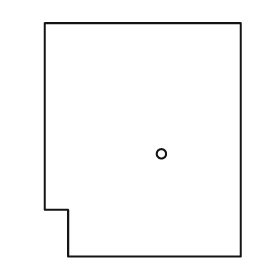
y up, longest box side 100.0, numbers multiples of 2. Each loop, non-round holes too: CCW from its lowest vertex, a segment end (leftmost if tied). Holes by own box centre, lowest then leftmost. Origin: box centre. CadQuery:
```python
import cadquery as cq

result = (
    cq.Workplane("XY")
    .moveTo(-32.0, -50.0)
    .lineTo(42.0, -50.0)
    .lineTo(42.0, 50.0)
    .lineTo(-42.0, 50.0)
    .lineTo(-42.0, -30.0)
    .lineTo(-32.0, -30.0)
    .close()
    .moveTo(8.0, -6.0)
    .circle(2.0)
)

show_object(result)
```